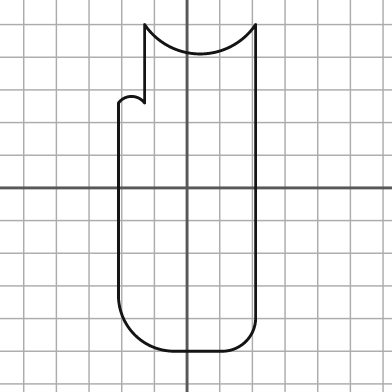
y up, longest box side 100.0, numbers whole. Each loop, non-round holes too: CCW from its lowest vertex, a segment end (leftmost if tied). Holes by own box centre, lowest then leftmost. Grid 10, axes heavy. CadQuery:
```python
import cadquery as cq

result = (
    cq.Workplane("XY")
    .moveTo(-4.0, -50.0)
    .lineTo(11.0, -50.0)
    .threePointArc((18.0, -47.0), (21.0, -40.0))
    .lineTo(21.0, 50.0)
    .threePointArc((4.0, 41.0), (-13.0, 50.0))
    .lineTo(-13.0, 26.0)
    .threePointArc((-17.0, 28.0), (-21.0, 26.0))
    .lineTo(-21.0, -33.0)
    .threePointArc((-16.0, -45.0), (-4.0, -50.0))
    .close()
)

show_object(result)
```